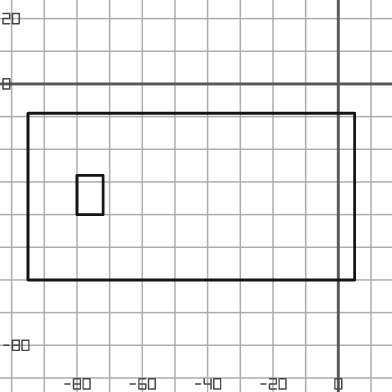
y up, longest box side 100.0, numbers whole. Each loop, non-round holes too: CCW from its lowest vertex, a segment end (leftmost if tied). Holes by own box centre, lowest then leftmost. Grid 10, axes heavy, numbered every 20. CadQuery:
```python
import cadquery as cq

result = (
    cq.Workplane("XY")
    .moveTo(-95.0, -60.0)
    .lineTo(5.0, -60.0)
    .lineTo(5.0, -9.0)
    .lineTo(-95.0, -9.0)
    .close()
    .moveTo(-80.0, -40.0)
    .lineTo(-72.0, -40.0)
    .lineTo(-72.0, -28.0)
    .lineTo(-80.0, -28.0)
    .close()
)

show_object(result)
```